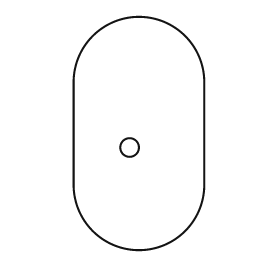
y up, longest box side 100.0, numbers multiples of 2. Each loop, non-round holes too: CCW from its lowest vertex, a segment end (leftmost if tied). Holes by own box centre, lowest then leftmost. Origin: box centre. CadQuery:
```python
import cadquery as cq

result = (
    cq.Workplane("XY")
    .moveTo(-28.0, -22.0)
    .threePointArc((0.0, -50.0), (28.0, -22.0))
    .lineTo(28.0, 22.0)
    .threePointArc((0.0, 50.0), (-28.0, 22.0))
    .close()
    .moveTo(-4.0, -6.0)
    .circle(4.0)
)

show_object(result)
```